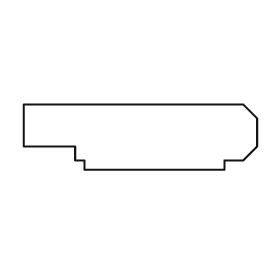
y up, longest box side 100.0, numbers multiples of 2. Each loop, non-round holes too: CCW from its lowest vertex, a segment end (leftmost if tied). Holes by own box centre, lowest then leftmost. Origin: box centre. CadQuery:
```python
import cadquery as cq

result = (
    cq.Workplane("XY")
    .moveTo(-24.0, -14.0)
    .lineTo(36.0, -14.0)
    .lineTo(36.0, -10.0)
    .lineTo(44.0, -10.0)
    .lineTo(50.0, -4.0)
    .lineTo(50.0, 8.0)
    .lineTo(44.0, 14.0)
    .lineTo(-50.0, 14.0)
    .lineTo(-50.0, -4.0)
    .lineTo(-28.0, -4.0)
    .lineTo(-28.0, -10.0)
    .lineTo(-24.0, -10.0)
    .close()
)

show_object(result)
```